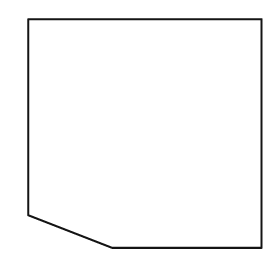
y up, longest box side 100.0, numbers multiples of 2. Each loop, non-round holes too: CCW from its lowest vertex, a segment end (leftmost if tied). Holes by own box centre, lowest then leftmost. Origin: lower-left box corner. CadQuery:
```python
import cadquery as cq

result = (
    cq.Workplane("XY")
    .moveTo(36.0, 0.0)
    .lineTo(100.0, 0.0)
    .lineTo(100.0, 98.0)
    .lineTo(0.0, 98.0)
    .lineTo(0.0, 14.0)
    .close()
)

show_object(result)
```